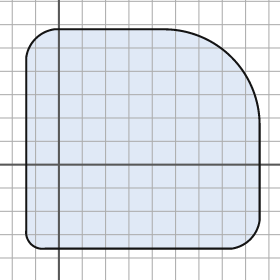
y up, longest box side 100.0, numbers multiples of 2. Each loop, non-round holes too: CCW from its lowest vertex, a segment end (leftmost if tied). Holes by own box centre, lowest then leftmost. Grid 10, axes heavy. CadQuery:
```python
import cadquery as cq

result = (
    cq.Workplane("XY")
    .moveTo(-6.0, -36.0)
    .lineTo(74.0, -36.0)
    .threePointArc((82.0, -32.0), (86.0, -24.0))
    .lineTo(86.0, 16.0)
    .threePointArc((74.0, 46.0), (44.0, 58.0))
    .lineTo(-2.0, 58.0)
    .threePointArc((-10.0, 54.0), (-14.0, 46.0))
    .lineTo(-14.0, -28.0)
    .threePointArc((-12.0, -34.0), (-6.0, -36.0))
    .close()
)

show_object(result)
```